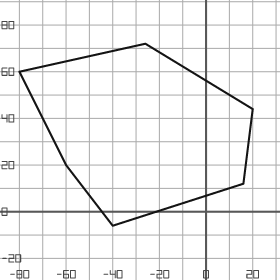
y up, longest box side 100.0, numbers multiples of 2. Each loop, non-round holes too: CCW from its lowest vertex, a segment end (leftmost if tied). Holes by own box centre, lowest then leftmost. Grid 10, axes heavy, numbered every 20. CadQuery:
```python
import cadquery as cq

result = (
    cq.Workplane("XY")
    .moveTo(-40.0, -6.0)
    .lineTo(16.0, 12.0)
    .lineTo(20.0, 44.0)
    .lineTo(-26.0, 72.0)
    .lineTo(-80.0, 60.0)
    .lineTo(-60.0, 20.0)
    .close()
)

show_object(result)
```